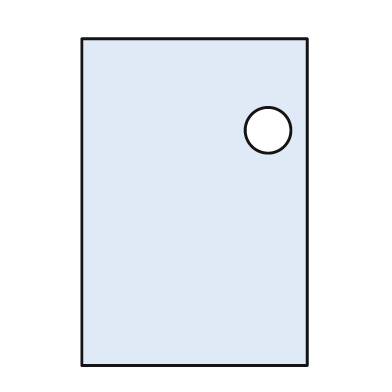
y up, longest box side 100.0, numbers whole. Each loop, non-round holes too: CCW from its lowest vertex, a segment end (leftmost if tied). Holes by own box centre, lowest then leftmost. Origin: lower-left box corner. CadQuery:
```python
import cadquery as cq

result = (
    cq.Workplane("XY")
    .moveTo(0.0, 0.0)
    .lineTo(69.0, 0.0)
    .lineTo(69.0, 100.0)
    .lineTo(0.0, 100.0)
    .close()
    .moveTo(57.0, 72.0)
    .circle(7.0)
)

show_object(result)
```